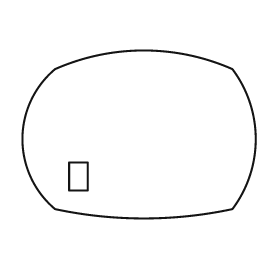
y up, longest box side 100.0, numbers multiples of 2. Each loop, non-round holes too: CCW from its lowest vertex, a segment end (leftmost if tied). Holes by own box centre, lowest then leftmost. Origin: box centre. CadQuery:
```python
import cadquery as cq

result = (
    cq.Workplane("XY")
    .moveTo(-36.0, -32.0)
    .threePointArc((2.0, -36.0), (40.0, -32.0))
    .threePointArc((50.0, -2.0), (40.0, 28.0))
    .threePointArc((2.0, 36.0), (-36.0, 28.0))
    .threePointArc((-50.0, -2.0), (-36.0, -32.0))
    .close()
    .moveTo(-30.0, -24.0)
    .lineTo(-22.0, -24.0)
    .lineTo(-22.0, -12.0)
    .lineTo(-30.0, -12.0)
    .close()
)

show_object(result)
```